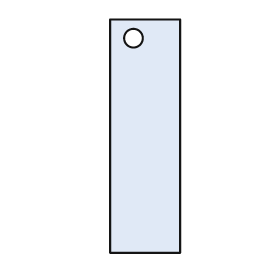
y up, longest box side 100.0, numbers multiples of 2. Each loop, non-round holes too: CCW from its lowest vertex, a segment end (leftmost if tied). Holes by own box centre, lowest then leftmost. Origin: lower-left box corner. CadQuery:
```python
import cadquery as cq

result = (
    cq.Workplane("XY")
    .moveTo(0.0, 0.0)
    .lineTo(30.0, 0.0)
    .lineTo(30.0, 100.0)
    .lineTo(0.0, 100.0)
    .close()
    .moveTo(10.0, 92.0)
    .circle(4.0)
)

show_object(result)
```